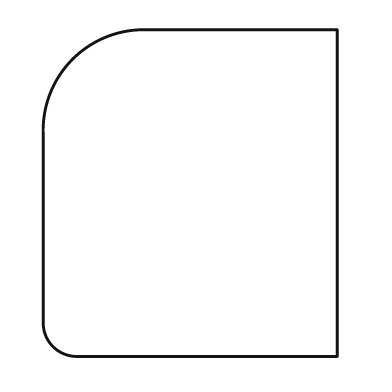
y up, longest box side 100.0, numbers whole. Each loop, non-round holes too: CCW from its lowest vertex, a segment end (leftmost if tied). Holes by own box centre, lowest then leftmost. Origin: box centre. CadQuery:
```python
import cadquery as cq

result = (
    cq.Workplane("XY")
    .moveTo(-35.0, -50.0)
    .lineTo(45.0, -50.0)
    .lineTo(45.0, 50.0)
    .lineTo(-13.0, 50.0)
    .threePointArc((-36.0, 41.0), (-45.0, 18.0))
    .lineTo(-45.0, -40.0)
    .threePointArc((-42.0, -47.0), (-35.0, -50.0))
    .close()
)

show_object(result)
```